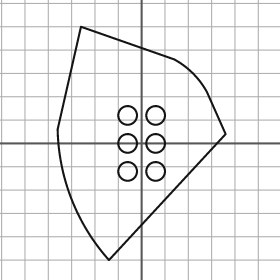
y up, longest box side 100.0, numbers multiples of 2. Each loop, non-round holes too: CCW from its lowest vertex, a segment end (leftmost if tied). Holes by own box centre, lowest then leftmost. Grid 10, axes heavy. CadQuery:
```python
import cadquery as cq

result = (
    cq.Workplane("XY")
    .moveTo(-14.0, -50.0)
    .lineTo(36.0, 4.0)
    .lineTo(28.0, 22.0)
    .threePointArc((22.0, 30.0), (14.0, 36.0))
    .lineTo(-26.0, 50.0)
    .lineTo(-36.0, 6.0)
    .threePointArc((-30.0, -24.0), (-14.0, -50.0))
    .close()
    .moveTo(-6.0, -12.0)
    .circle(4.0)
    .moveTo(6.0, -12.0)
    .circle(4.0)
    .moveTo(-6.0, 0.0)
    .circle(4.0)
    .moveTo(6.0, 0.0)
    .circle(4.0)
    .moveTo(-6.0, 12.0)
    .circle(4.0)
    .moveTo(6.0, 12.0)
    .circle(4.0)
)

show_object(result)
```